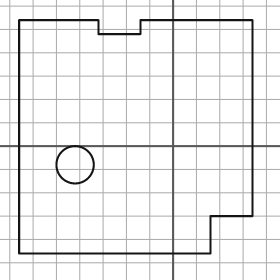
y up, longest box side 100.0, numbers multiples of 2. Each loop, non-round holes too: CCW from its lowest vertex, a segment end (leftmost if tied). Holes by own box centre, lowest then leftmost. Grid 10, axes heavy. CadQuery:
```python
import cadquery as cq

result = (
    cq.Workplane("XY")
    .moveTo(-66.0, -46.0)
    .lineTo(16.0, -46.0)
    .lineTo(16.0, -30.0)
    .lineTo(34.0, -30.0)
    .lineTo(34.0, 54.0)
    .lineTo(-14.0, 54.0)
    .lineTo(-14.0, 48.0)
    .lineTo(-32.0, 48.0)
    .lineTo(-32.0, 54.0)
    .lineTo(-66.0, 54.0)
    .close()
    .moveTo(-42.0, -8.0)
    .circle(8.0)
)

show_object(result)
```